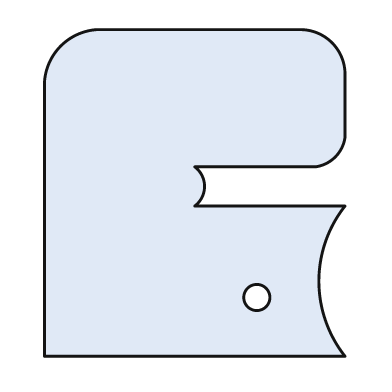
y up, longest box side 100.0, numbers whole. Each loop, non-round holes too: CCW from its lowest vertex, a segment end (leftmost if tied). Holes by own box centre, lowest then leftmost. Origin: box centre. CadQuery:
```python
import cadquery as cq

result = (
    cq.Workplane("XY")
    .moveTo(-46.0, -50.0)
    .lineTo(46.0, -50.0)
    .threePointArc((38.0, -27.0), (46.0, -4.0))
    .lineTo(0.0, -4.0)
    .threePointArc((3.0, 2.0), (0.0, 8.0))
    .lineTo(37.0, 8.0)
    .threePointArc((43.0, 11.0), (46.0, 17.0))
    .lineTo(46.0, 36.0)
    .threePointArc((42.0, 46.0), (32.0, 50.0))
    .lineTo(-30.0, 50.0)
    .threePointArc((-41.0, 45.0), (-46.0, 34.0))
    .close()
    .moveTo(19.0, -32.0)
    .circle(4.0)
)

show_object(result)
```